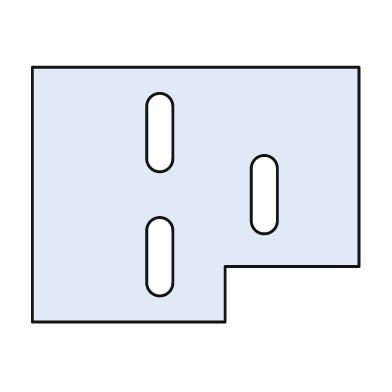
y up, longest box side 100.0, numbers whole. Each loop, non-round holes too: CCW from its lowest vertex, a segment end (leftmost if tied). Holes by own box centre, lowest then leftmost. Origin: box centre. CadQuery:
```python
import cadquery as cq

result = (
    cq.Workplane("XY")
    .moveTo(-50.0, -39.0)
    .lineTo(9.0, -39.0)
    .lineTo(9.0, -22.0)
    .lineTo(50.0, -22.0)
    .lineTo(50.0, 39.0)
    .lineTo(-50.0, 39.0)
    .close()
    .moveTo(-15.0, -27.0)
    .threePointArc((-11.0, -31.0), (-7.0, -27.0))
    .lineTo(-7.0, -11.0)
    .threePointArc((-11.0, -7.0), (-15.0, -11.0))
    .close()
    .moveTo(17.0, -8.0)
    .threePointArc((21.0, -12.0), (25.0, -8.0))
    .lineTo(25.0, 8.0)
    .threePointArc((21.0, 12.0), (17.0, 8.0))
    .close()
    .moveTo(-15.0, 11.0)
    .threePointArc((-11.0, 7.0), (-7.0, 11.0))
    .lineTo(-7.0, 27.0)
    .threePointArc((-11.0, 31.0), (-15.0, 27.0))
    .close()
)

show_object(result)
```